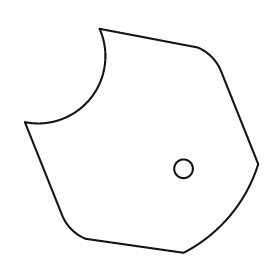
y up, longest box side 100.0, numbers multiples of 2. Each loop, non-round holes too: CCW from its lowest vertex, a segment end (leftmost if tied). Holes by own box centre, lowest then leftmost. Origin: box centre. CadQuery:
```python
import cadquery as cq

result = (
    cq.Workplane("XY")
    .moveTo(18.0, -48.0)
    .threePointArc((38.0, -32.0), (50.0, -10.0))
    .lineTo(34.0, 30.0)
    .threePointArc((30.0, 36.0), (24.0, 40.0))
    .lineTo(-18.0, 48.0)
    .threePointArc((-22.0, 18.0), (-50.0, 8.0))
    .lineTo(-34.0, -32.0)
    .threePointArc((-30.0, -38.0), (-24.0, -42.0))
    .close()
    .moveTo(18.0, -12.0)
    .circle(4.0)
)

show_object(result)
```